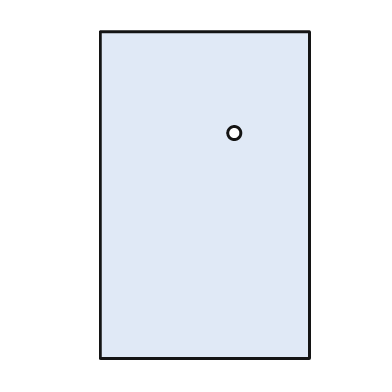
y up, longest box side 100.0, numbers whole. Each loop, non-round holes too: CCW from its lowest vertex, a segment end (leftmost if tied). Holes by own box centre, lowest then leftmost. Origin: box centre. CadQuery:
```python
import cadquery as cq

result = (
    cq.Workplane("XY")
    .moveTo(-32.0, -50.0)
    .lineTo(32.0, -50.0)
    .lineTo(32.0, 50.0)
    .lineTo(-32.0, 50.0)
    .close()
    .moveTo(9.0, 19.0)
    .circle(2.0)
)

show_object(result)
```